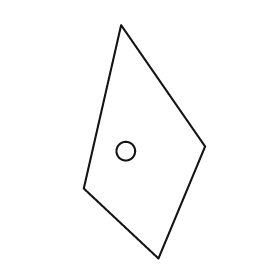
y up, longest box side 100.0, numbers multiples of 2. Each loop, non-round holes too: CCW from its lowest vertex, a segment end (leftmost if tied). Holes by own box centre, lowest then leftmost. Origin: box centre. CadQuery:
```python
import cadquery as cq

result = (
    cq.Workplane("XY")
    .moveTo(6.0, -50.0)
    .lineTo(26.0, -2.0)
    .lineTo(-10.0, 50.0)
    .lineTo(-26.0, -20.0)
    .close()
    .moveTo(-8.0, -4.0)
    .circle(4.0)
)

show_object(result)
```